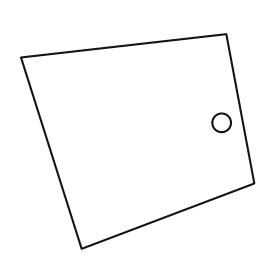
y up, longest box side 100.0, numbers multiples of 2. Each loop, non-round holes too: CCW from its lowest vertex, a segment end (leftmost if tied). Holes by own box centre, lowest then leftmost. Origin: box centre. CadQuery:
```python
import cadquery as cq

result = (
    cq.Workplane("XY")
    .moveTo(-24.0, -46.0)
    .lineTo(50.0, -18.0)
    .lineTo(38.0, 46.0)
    .lineTo(-50.0, 36.0)
    .close()
    .moveTo(36.0, 8.0)
    .circle(4.0)
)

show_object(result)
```